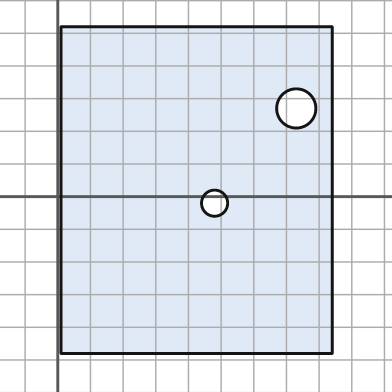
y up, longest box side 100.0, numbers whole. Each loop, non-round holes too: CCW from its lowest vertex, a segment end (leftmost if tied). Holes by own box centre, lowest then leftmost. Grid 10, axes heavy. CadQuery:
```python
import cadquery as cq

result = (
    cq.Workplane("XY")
    .moveTo(1.0, -48.0)
    .lineTo(84.0, -48.0)
    .lineTo(84.0, 52.0)
    .lineTo(1.0, 52.0)
    .close()
    .moveTo(48.0, -2.0)
    .circle(4.0)
    .moveTo(73.0, 27.0)
    .circle(6.0)
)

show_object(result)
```